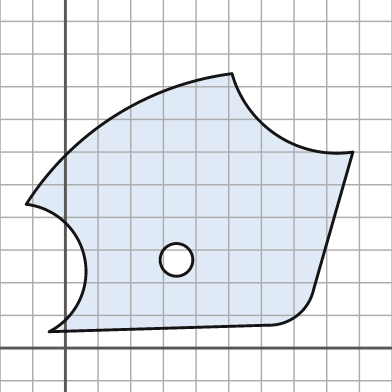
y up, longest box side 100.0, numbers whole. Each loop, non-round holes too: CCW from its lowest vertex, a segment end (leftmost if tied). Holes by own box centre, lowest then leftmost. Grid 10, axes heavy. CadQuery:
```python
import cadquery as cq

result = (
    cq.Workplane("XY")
    .moveTo(-5.0, 5.0)
    .lineTo(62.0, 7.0)
    .threePointArc((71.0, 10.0), (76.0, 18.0))
    .lineTo(88.0, 60.0)
    .threePointArc((65.0, 65.0), (51.0, 84.0))
    .threePointArc((15.0, 71.0), (-12.0, 44.0))
    .threePointArc((6.0, 27.0), (-5.0, 5.0))
    .close()
    .moveTo(34.0, 27.0)
    .circle(5.0)
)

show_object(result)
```